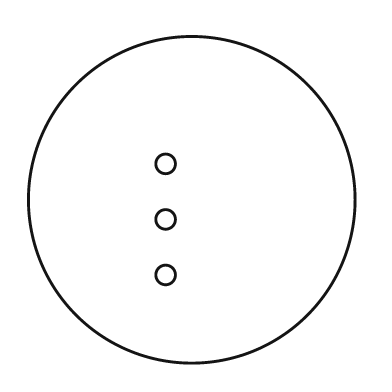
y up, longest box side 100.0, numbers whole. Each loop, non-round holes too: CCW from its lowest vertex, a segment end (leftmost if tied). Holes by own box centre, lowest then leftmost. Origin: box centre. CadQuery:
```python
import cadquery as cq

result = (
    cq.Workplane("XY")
    .moveTo(0.0, 0.0)
    .circle(50.0)
    .moveTo(-8.0, -23.0)
    .circle(3.0)
    .moveTo(-8.0, -6.0)
    .circle(3.0)
    .moveTo(-8.0, 11.0)
    .circle(3.0)
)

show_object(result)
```